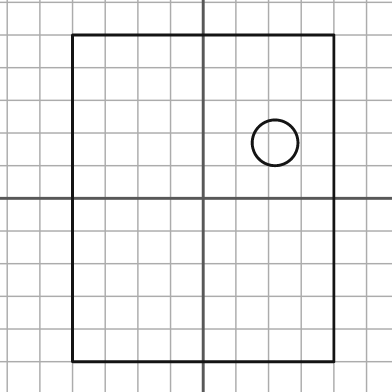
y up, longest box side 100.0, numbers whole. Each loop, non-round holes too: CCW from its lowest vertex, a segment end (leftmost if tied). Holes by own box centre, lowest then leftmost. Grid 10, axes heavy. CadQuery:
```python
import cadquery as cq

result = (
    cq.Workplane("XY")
    .moveTo(-40.0, -50.0)
    .lineTo(40.0, -50.0)
    .lineTo(40.0, 50.0)
    .lineTo(-40.0, 50.0)
    .close()
    .moveTo(22.0, 17.0)
    .circle(7.0)
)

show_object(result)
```